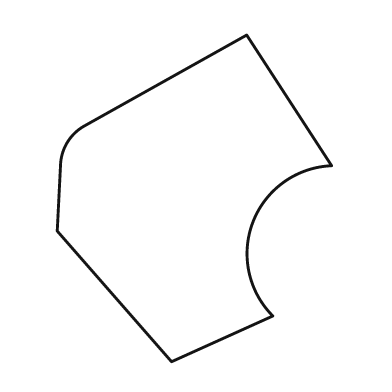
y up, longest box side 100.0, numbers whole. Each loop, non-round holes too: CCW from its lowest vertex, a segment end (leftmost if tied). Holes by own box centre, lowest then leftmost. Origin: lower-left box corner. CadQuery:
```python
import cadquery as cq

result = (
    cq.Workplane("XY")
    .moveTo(35.0, 0.0)
    .lineTo(66.0, 14.0)
    .threePointArc((60.0, 43.0), (84.0, 60.0))
    .lineTo(58.0, 100.0)
    .lineTo(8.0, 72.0)
    .threePointArc((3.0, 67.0), (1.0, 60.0))
    .lineTo(0.0, 40.0)
    .close()
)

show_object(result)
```